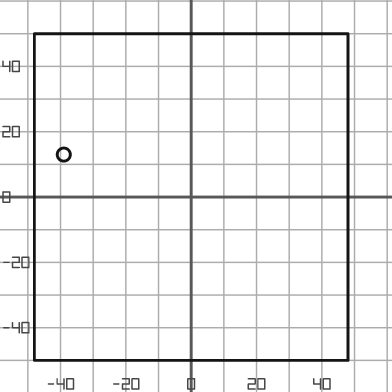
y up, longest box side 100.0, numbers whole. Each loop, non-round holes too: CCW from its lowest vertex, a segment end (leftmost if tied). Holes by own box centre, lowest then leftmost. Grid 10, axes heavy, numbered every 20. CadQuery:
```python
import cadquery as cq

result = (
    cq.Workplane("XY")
    .moveTo(-48.0, -50.0)
    .lineTo(48.0, -50.0)
    .lineTo(48.0, 50.0)
    .lineTo(-48.0, 50.0)
    .close()
    .moveTo(-39.0, 13.0)
    .circle(2.0)
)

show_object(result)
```